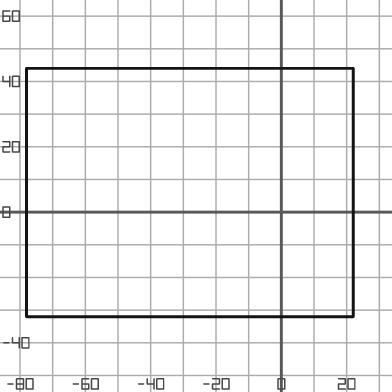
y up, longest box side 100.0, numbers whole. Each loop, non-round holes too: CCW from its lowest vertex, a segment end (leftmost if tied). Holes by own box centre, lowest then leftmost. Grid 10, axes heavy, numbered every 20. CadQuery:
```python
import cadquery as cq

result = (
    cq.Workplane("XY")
    .moveTo(-78.0, -32.0)
    .lineTo(22.0, -32.0)
    .lineTo(22.0, 44.0)
    .lineTo(-78.0, 44.0)
    .close()
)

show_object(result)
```